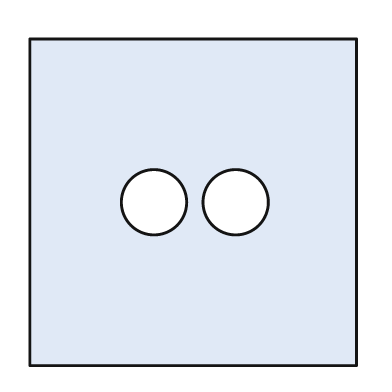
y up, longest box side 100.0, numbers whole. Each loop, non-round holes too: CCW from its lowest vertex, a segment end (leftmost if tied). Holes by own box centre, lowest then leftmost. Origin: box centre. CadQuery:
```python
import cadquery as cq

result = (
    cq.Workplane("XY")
    .moveTo(-50.0, -50.0)
    .lineTo(50.0, -50.0)
    .lineTo(50.0, 50.0)
    .lineTo(-50.0, 50.0)
    .close()
    .moveTo(-12.0, 0.0)
    .circle(10.0)
    .moveTo(13.0, 0.0)
    .circle(10.0)
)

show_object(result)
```